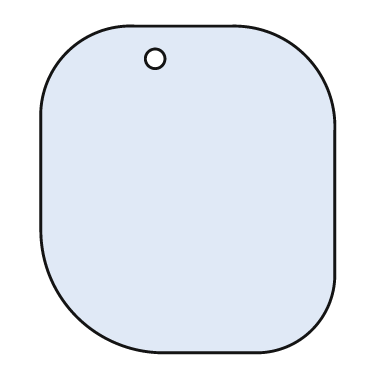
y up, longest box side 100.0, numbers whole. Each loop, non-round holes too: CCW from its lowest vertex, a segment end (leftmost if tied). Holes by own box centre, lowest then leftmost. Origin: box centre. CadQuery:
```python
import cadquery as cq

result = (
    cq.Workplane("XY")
    .moveTo(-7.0, -50.0)
    .lineTo(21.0, -50.0)
    .threePointArc((38.0, -43.0), (45.0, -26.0))
    .lineTo(45.0, 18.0)
    .threePointArc((36.0, 41.0), (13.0, 50.0))
    .lineTo(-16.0, 50.0)
    .threePointArc((-37.0, 42.0), (-45.0, 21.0))
    .lineTo(-45.0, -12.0)
    .threePointArc((-34.0, -39.0), (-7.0, -50.0))
    .close()
    .moveTo(-10.0, 40.0)
    .circle(3.0)
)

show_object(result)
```